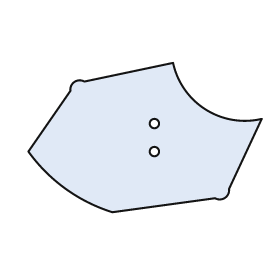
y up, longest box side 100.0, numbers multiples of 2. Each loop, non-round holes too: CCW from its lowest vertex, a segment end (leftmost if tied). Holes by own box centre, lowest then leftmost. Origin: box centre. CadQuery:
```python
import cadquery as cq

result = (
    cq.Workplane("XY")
    .moveTo(-14.0, -32.0)
    .lineTo(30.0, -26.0)
    .threePointArc((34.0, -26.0), (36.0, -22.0))
    .lineTo(50.0, 8.0)
    .threePointArc((26.0, 12.0), (12.0, 32.0))
    .lineTo(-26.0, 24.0)
    .threePointArc((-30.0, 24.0), (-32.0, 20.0))
    .lineTo(-50.0, -6.0)
    .threePointArc((-34.0, -22.0), (-14.0, -32.0))
    .close()
    .moveTo(4.0, -6.0)
    .circle(2.0)
    .moveTo(4.0, 6.0)
    .circle(2.0)
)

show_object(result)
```